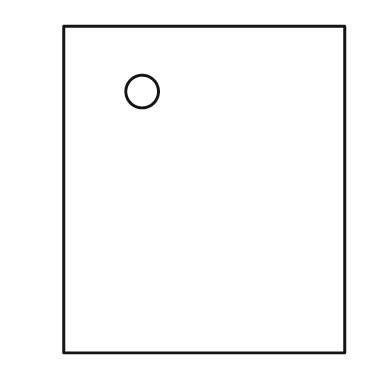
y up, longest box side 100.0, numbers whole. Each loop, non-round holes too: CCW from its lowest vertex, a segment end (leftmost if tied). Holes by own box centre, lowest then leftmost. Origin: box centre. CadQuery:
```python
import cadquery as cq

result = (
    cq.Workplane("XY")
    .moveTo(-43.0, -50.0)
    .lineTo(43.0, -50.0)
    .lineTo(43.0, 50.0)
    .lineTo(-43.0, 50.0)
    .close()
    .moveTo(-19.0, 30.0)
    .circle(5.0)
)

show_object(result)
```